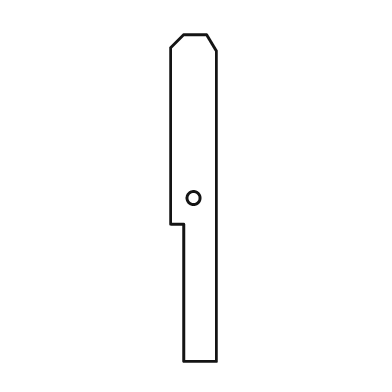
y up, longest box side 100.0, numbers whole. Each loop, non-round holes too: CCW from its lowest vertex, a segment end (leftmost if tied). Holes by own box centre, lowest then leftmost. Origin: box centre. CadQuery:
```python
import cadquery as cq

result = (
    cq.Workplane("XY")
    .moveTo(-3.0, -50.0)
    .lineTo(7.0, -50.0)
    .lineTo(7.0, 45.0)
    .lineTo(4.0, 50.0)
    .lineTo(-3.0, 50.0)
    .lineTo(-7.0, 46.0)
    .lineTo(-7.0, -8.0)
    .lineTo(-3.0, -8.0)
    .close()
    .moveTo(0.0, 0.0)
    .circle(2.0)
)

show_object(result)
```